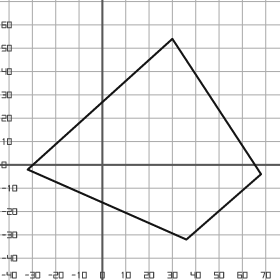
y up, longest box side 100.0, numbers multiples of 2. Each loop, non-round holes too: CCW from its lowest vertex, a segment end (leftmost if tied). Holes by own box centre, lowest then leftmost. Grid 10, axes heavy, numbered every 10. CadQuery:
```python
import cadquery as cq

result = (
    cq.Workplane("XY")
    .moveTo(36.0, -32.0)
    .lineTo(68.0, -4.0)
    .lineTo(30.0, 54.0)
    .lineTo(-32.0, -2.0)
    .close()
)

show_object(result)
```